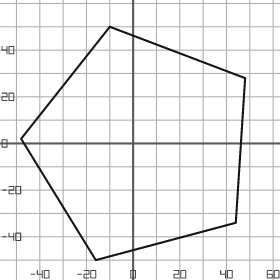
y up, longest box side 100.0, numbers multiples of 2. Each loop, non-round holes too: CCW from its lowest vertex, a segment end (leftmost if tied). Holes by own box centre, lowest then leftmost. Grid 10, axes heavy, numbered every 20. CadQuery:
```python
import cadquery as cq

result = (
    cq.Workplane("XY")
    .moveTo(-16.0, -50.0)
    .lineTo(44.0, -34.0)
    .lineTo(48.0, 28.0)
    .lineTo(-10.0, 50.0)
    .lineTo(-48.0, 2.0)
    .close()
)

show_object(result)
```